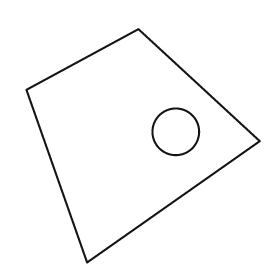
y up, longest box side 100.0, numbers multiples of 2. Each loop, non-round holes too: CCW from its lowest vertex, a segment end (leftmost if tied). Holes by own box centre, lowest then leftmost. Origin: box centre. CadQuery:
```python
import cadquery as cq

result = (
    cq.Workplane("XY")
    .moveTo(-24.0, -50.0)
    .lineTo(50.0, 2.0)
    .lineTo(-2.0, 50.0)
    .lineTo(-50.0, 24.0)
    .close()
    .moveTo(14.0, 6.0)
    .circle(10.0)
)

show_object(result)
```